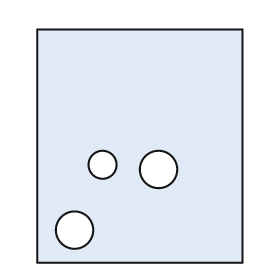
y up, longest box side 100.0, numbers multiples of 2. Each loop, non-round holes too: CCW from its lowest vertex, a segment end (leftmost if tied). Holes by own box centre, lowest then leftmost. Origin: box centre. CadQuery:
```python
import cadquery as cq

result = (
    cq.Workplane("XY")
    .moveTo(-44.0, -50.0)
    .lineTo(44.0, -50.0)
    .lineTo(44.0, 50.0)
    .lineTo(-44.0, 50.0)
    .close()
    .moveTo(-28.0, -36.0)
    .circle(8.0)
    .moveTo(8.0, -10.0)
    .circle(8.0)
    .moveTo(-16.0, -8.0)
    .circle(6.0)
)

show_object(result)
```